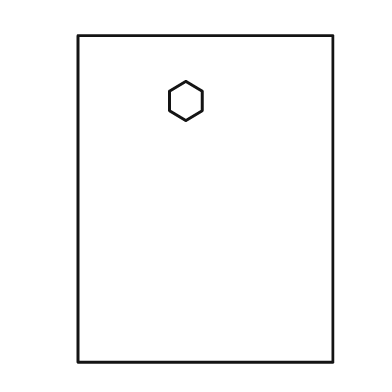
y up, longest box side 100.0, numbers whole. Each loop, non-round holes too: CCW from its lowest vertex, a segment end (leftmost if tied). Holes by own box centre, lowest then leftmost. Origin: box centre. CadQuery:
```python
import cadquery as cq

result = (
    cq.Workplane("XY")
    .moveTo(-39.0, -50.0)
    .lineTo(39.0, -50.0)
    .lineTo(39.0, 50.0)
    .lineTo(-39.0, 50.0)
    .close()
    .moveTo(-6.0, 24.0)
    .lineTo(-1.0, 27.0)
    .lineTo(-1.0, 33.0)
    .lineTo(-6.0, 36.0)
    .lineTo(-11.0, 33.0)
    .lineTo(-11.0, 27.0)
    .close()
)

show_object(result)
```